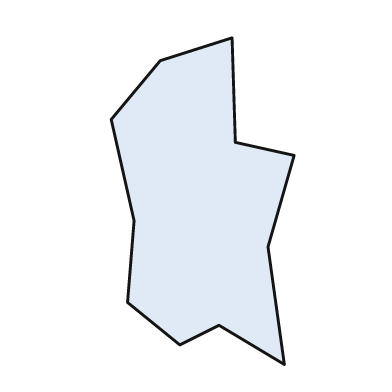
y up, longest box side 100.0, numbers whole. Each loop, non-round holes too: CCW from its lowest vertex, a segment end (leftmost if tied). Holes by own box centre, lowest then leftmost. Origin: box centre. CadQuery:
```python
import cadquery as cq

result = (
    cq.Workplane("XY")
    .moveTo(25.0, -50.0)
    .lineTo(20.0, -14.0)
    .lineTo(28.0, 14.0)
    .lineTo(10.0, 18.0)
    .lineTo(9.0, 50.0)
    .lineTo(-13.0, 43.0)
    .lineTo(-28.0, 25.0)
    .lineTo(-21.0, -6.0)
    .lineTo(-23.0, -31.0)
    .lineTo(-7.0, -44.0)
    .lineTo(5.0, -38.0)
    .close()
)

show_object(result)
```